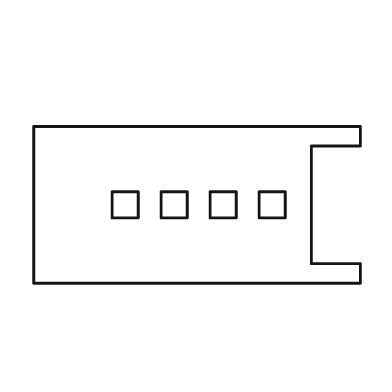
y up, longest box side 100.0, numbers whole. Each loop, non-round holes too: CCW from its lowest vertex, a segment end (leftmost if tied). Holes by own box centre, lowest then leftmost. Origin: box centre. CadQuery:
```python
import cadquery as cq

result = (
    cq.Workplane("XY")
    .moveTo(-50.0, -24.0)
    .lineTo(50.0, -24.0)
    .lineTo(50.0, -18.0)
    .lineTo(35.0, -18.0)
    .lineTo(35.0, 18.0)
    .lineTo(50.0, 18.0)
    .lineTo(50.0, 24.0)
    .lineTo(-50.0, 24.0)
    .close()
    .moveTo(-26.0, -4.0)
    .lineTo(-18.0, -4.0)
    .lineTo(-18.0, 4.0)
    .lineTo(-26.0, 4.0)
    .close()
    .moveTo(-11.0, -4.0)
    .lineTo(-3.0, -4.0)
    .lineTo(-3.0, 4.0)
    .lineTo(-11.0, 4.0)
    .close()
    .moveTo(4.0, -4.0)
    .lineTo(12.0, -4.0)
    .lineTo(12.0, 4.0)
    .lineTo(4.0, 4.0)
    .close()
    .moveTo(19.0, -4.0)
    .lineTo(27.0, -4.0)
    .lineTo(27.0, 4.0)
    .lineTo(19.0, 4.0)
    .close()
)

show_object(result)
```